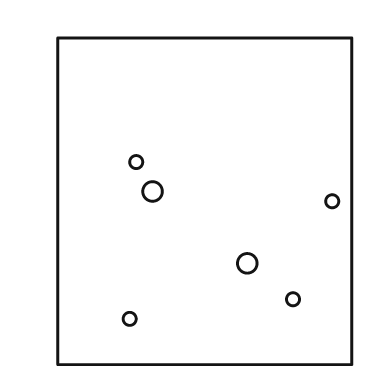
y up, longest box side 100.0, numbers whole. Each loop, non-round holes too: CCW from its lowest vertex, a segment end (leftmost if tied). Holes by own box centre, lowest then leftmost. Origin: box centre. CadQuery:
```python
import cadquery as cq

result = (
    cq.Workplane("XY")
    .moveTo(-45.0, -50.0)
    .lineTo(45.0, -50.0)
    .lineTo(45.0, 50.0)
    .lineTo(-45.0, 50.0)
    .close()
    .moveTo(-23.0, -36.0)
    .circle(2.0)
    .moveTo(27.0, -30.0)
    .circle(2.0)
    .moveTo(13.0, -19.0)
    .circle(3.0)
    .moveTo(39.0, 0.0)
    .circle(2.0)
    .moveTo(-16.0, 3.0)
    .circle(3.0)
    .moveTo(-21.0, 12.0)
    .circle(2.0)
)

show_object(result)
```